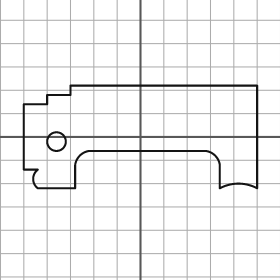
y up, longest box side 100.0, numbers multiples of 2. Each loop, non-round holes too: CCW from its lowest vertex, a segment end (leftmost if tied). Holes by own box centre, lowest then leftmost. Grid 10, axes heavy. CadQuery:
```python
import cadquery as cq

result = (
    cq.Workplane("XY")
    .moveTo(-44.0, -22.0)
    .lineTo(-28.0, -22.0)
    .lineTo(-28.0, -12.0)
    .threePointArc((-26.0, -8.0), (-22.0, -6.0))
    .lineTo(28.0, -6.0)
    .threePointArc((32.0, -8.0), (34.0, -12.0))
    .lineTo(34.0, -22.0)
    .threePointArc((42.0, -20.0), (50.0, -22.0))
    .lineTo(50.0, 22.0)
    .lineTo(-30.0, 22.0)
    .lineTo(-30.0, 18.0)
    .lineTo(-40.0, 18.0)
    .lineTo(-40.0, 14.0)
    .lineTo(-50.0, 14.0)
    .lineTo(-50.0, -14.0)
    .lineTo(-44.0, -14.0)
    .threePointArc((-46.0, -18.0), (-44.0, -22.0))
    .close()
    .moveTo(-36.0, -2.0)
    .circle(4.0)
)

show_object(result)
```